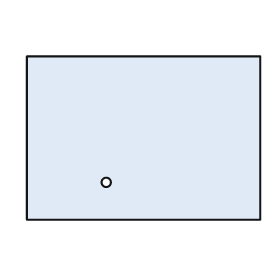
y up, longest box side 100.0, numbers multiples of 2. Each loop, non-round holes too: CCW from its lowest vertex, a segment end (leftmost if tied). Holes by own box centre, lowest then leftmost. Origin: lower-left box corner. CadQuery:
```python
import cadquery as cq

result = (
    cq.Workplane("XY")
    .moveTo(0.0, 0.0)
    .lineTo(100.0, 0.0)
    .lineTo(100.0, 70.0)
    .lineTo(0.0, 70.0)
    .close()
    .moveTo(34.0, 16.0)
    .circle(2.0)
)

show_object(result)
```